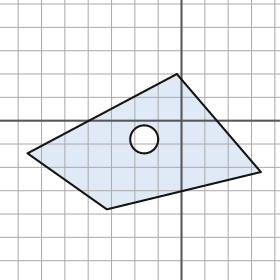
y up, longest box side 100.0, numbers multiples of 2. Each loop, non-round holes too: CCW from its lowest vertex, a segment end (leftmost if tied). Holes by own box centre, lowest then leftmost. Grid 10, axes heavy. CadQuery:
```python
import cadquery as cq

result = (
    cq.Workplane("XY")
    .moveTo(-32.0, -38.0)
    .lineTo(34.0, -22.0)
    .lineTo(-2.0, 20.0)
    .lineTo(-66.0, -14.0)
    .close()
    .moveTo(-16.0, -8.0)
    .circle(6.0)
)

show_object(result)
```